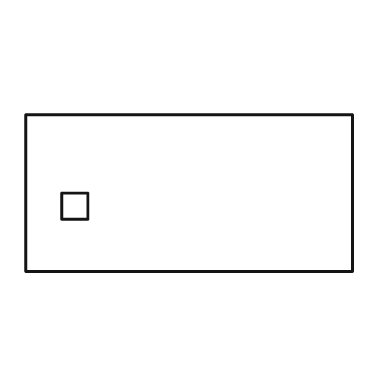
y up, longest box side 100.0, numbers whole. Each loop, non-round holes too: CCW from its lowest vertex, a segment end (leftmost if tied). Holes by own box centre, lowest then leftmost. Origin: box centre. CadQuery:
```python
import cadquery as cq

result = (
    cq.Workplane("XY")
    .moveTo(-50.0, -24.0)
    .lineTo(50.0, -24.0)
    .lineTo(50.0, 24.0)
    .lineTo(-50.0, 24.0)
    .close()
    .moveTo(-39.0, -8.0)
    .lineTo(-31.0, -8.0)
    .lineTo(-31.0, 0.0)
    .lineTo(-39.0, 0.0)
    .close()
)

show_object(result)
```